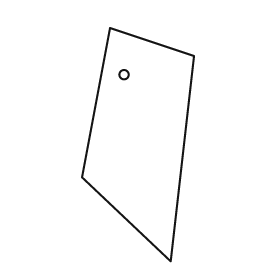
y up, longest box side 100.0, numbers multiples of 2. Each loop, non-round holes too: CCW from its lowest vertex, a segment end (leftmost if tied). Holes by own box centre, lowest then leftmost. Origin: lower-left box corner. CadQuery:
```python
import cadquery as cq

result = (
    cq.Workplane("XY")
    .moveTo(38.0, 0.0)
    .lineTo(48.0, 88.0)
    .lineTo(12.0, 100.0)
    .lineTo(0.0, 36.0)
    .close()
    .moveTo(18.0, 80.0)
    .circle(2.0)
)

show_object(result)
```